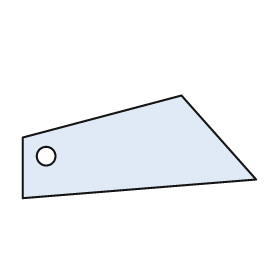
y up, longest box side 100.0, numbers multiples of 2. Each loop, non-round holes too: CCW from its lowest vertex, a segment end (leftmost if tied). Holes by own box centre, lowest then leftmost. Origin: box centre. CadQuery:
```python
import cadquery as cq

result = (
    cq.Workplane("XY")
    .moveTo(-50.0, -22.0)
    .lineTo(50.0, -14.0)
    .lineTo(18.0, 22.0)
    .lineTo(-50.0, 4.0)
    .close()
    .moveTo(-40.0, -4.0)
    .circle(4.0)
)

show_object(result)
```